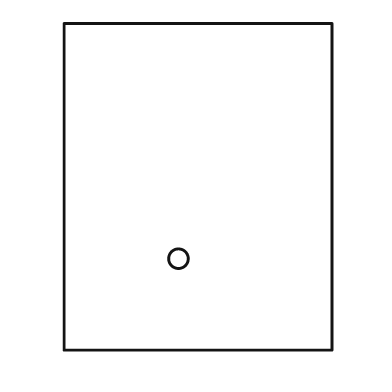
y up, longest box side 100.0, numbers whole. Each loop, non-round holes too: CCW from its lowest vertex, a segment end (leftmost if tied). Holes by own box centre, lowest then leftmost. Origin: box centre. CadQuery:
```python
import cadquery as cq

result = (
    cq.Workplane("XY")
    .moveTo(-41.0, -50.0)
    .lineTo(41.0, -50.0)
    .lineTo(41.0, 50.0)
    .lineTo(-41.0, 50.0)
    .close()
    .moveTo(-6.0, -22.0)
    .circle(3.0)
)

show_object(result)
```